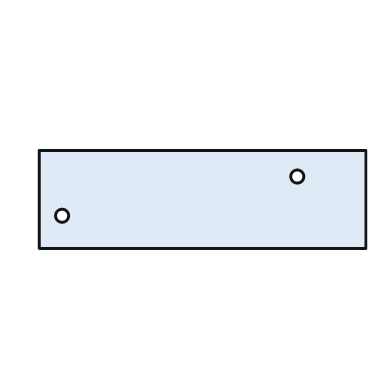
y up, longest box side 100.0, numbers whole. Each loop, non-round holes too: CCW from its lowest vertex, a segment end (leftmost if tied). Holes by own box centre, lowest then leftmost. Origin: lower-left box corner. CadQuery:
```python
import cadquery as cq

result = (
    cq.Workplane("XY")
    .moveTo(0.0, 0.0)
    .lineTo(100.0, 0.0)
    .lineTo(100.0, 30.0)
    .lineTo(0.0, 30.0)
    .close()
    .moveTo(7.0, 10.0)
    .circle(2.0)
    .moveTo(79.0, 22.0)
    .circle(2.0)
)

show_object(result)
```